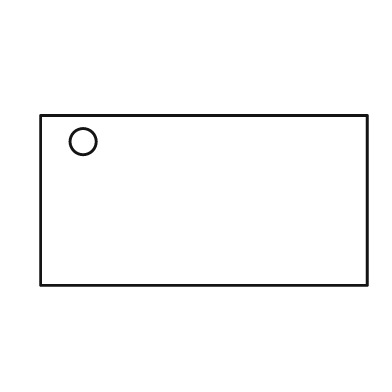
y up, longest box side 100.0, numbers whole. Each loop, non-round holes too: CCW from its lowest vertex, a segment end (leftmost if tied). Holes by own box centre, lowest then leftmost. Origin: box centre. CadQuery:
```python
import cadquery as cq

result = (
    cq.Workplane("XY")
    .moveTo(-50.0, -26.0)
    .lineTo(50.0, -26.0)
    .lineTo(50.0, 26.0)
    .lineTo(-50.0, 26.0)
    .close()
    .moveTo(-37.0, 18.0)
    .circle(4.0)
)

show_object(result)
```